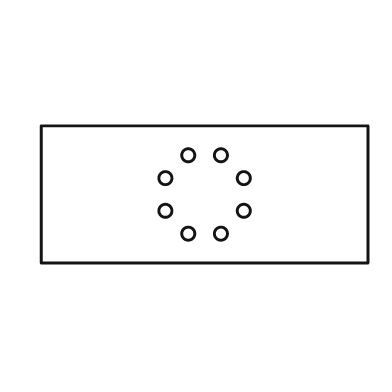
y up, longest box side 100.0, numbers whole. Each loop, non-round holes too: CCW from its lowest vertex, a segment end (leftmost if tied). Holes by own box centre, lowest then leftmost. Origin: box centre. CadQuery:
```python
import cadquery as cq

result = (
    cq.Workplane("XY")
    .moveTo(-50.0, -21.0)
    .lineTo(50.0, -21.0)
    .lineTo(50.0, 21.0)
    .lineTo(-50.0, 21.0)
    .close()
    .moveTo(-5.0, -12.0)
    .circle(2.0)
    .moveTo(5.0, -12.0)
    .circle(2.0)
    .moveTo(-12.0, -5.0)
    .circle(2.0)
    .moveTo(12.0, -5.0)
    .circle(2.0)
    .moveTo(-12.0, 5.0)
    .circle(2.0)
    .moveTo(12.0, 5.0)
    .circle(2.0)
    .moveTo(-5.0, 12.0)
    .circle(2.0)
    .moveTo(5.0, 12.0)
    .circle(2.0)
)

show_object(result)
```